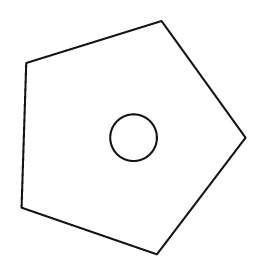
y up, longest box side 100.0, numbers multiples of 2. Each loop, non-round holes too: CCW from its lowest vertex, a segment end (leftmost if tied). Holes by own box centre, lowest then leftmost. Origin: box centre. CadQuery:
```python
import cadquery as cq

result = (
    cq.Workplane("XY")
    .moveTo(10.0, -50.0)
    .lineTo(48.0, 0.0)
    .lineTo(12.0, 50.0)
    .lineTo(-46.0, 32.0)
    .lineTo(-48.0, -30.0)
    .close()
    .moveTo(0.0, 0.0)
    .circle(10.0)
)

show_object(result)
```